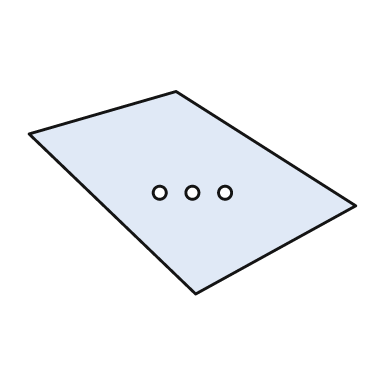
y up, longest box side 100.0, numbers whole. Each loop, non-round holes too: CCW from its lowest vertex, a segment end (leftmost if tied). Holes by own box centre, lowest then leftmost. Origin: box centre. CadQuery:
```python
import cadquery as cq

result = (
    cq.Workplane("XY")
    .moveTo(1.0, -31.0)
    .lineTo(50.0, -4.0)
    .lineTo(-5.0, 31.0)
    .lineTo(-50.0, 18.0)
    .close()
    .moveTo(-10.0, 0.0)
    .circle(2.0)
    .moveTo(0.0, 0.0)
    .circle(2.0)
    .moveTo(10.0, 0.0)
    .circle(2.0)
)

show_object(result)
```